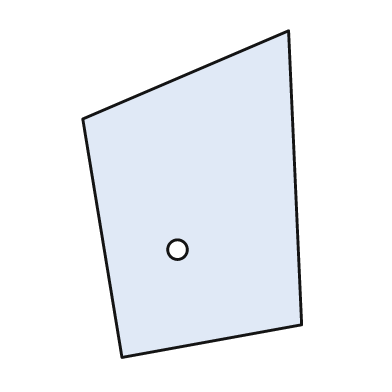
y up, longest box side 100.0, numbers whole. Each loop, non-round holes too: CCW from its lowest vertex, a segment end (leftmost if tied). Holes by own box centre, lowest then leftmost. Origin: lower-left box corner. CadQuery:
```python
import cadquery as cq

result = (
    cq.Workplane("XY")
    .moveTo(12.0, 0.0)
    .lineTo(67.0, 10.0)
    .lineTo(63.0, 100.0)
    .lineTo(0.0, 73.0)
    .close()
    .moveTo(29.0, 33.0)
    .circle(3.0)
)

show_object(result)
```